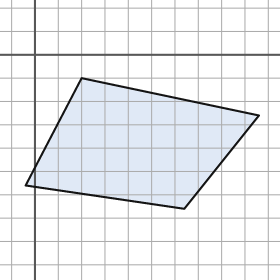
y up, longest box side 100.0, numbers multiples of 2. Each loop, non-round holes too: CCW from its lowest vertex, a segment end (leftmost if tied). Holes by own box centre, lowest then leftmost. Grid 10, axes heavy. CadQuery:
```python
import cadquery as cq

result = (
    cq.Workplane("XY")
    .moveTo(64.0, -66.0)
    .lineTo(96.0, -26.0)
    .lineTo(20.0, -10.0)
    .lineTo(-4.0, -56.0)
    .close()
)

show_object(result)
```